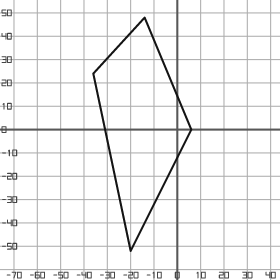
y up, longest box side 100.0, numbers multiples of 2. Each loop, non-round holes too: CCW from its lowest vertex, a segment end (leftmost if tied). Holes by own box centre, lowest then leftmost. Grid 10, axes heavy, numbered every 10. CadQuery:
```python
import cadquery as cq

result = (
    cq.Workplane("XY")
    .moveTo(-20.0, -52.0)
    .lineTo(6.0, 0.0)
    .lineTo(-14.0, 48.0)
    .lineTo(-36.0, 24.0)
    .close()
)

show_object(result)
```